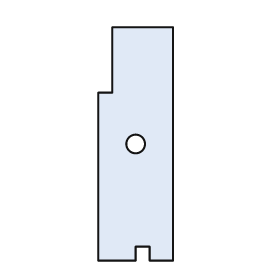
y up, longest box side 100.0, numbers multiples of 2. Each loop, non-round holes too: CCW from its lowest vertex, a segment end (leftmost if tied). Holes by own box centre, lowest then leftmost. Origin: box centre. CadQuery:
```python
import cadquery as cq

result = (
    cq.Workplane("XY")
    .moveTo(-16.0, -50.0)
    .lineTo(0.0, -50.0)
    .lineTo(0.0, -44.0)
    .lineTo(6.0, -44.0)
    .lineTo(6.0, -50.0)
    .lineTo(16.0, -50.0)
    .lineTo(16.0, 50.0)
    .lineTo(-10.0, 50.0)
    .lineTo(-10.0, 22.0)
    .lineTo(-16.0, 22.0)
    .close()
    .moveTo(0.0, 0.0)
    .circle(4.0)
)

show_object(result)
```